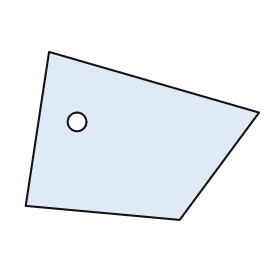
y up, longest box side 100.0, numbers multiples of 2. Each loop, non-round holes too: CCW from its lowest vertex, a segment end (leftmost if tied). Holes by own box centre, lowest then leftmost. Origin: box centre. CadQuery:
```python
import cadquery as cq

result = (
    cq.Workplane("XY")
    .moveTo(16.0, -36.0)
    .lineTo(50.0, 10.0)
    .lineTo(-40.0, 36.0)
    .lineTo(-50.0, -30.0)
    .close()
    .moveTo(-28.0, 6.0)
    .circle(4.0)
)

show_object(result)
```